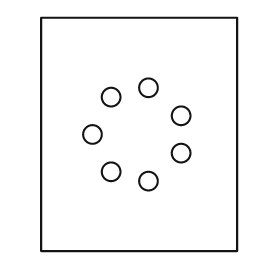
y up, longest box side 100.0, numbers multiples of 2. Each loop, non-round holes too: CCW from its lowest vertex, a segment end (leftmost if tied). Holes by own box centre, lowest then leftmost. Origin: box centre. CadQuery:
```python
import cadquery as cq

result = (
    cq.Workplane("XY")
    .moveTo(-42.0, -50.0)
    .lineTo(42.0, -50.0)
    .lineTo(42.0, 50.0)
    .lineTo(-42.0, 50.0)
    .close()
    .moveTo(4.0, -20.0)
    .circle(4.0)
    .moveTo(-12.0, -16.0)
    .circle(4.0)
    .moveTo(18.0, -8.0)
    .circle(4.0)
    .moveTo(-20.0, 0.0)
    .circle(4.0)
    .moveTo(18.0, 8.0)
    .circle(4.0)
    .moveTo(-12.0, 16.0)
    .circle(4.0)
    .moveTo(4.0, 20.0)
    .circle(4.0)
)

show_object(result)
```